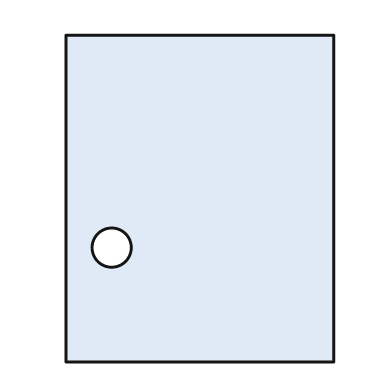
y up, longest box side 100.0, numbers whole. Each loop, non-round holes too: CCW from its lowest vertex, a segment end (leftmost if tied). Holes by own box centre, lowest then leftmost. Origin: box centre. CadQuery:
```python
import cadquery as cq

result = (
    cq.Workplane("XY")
    .moveTo(-41.0, -50.0)
    .lineTo(41.0, -50.0)
    .lineTo(41.0, 50.0)
    .lineTo(-41.0, 50.0)
    .close()
    .moveTo(-27.0, -15.0)
    .circle(6.0)
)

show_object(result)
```